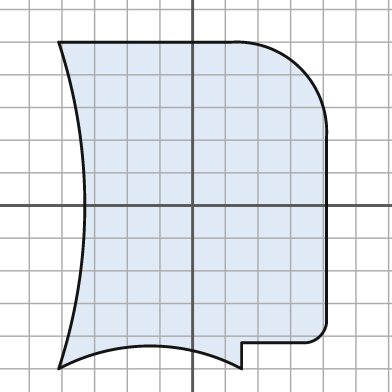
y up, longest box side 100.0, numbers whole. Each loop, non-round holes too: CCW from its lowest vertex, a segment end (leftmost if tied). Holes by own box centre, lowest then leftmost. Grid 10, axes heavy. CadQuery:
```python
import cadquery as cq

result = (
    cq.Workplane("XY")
    .moveTo(-41.0, -50.0)
    .threePointArc((-13.0, -43.0), (15.0, -50.0))
    .lineTo(15.0, -42.0)
    .lineTo(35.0, -42.0)
    .threePointArc((39.0, -40.0), (41.0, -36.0))
    .lineTo(41.0, 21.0)
    .threePointArc((33.0, 42.0), (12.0, 50.0))
    .lineTo(-41.0, 50.0)
    .threePointArc((-33.0, 0.0), (-41.0, -50.0))
    .close()
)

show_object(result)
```